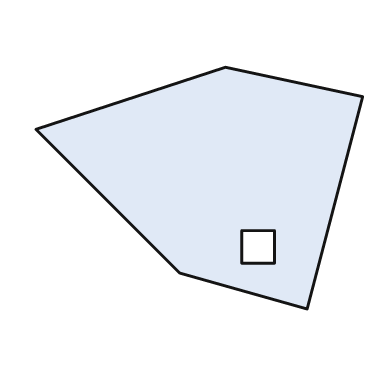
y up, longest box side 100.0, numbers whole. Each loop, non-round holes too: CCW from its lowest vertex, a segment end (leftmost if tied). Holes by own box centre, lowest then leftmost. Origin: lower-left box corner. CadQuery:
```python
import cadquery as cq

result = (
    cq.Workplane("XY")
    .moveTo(83.0, 0.0)
    .lineTo(100.0, 65.0)
    .lineTo(58.0, 74.0)
    .lineTo(0.0, 55.0)
    .lineTo(44.0, 11.0)
    .close()
    .moveTo(63.0, 14.0)
    .lineTo(73.0, 14.0)
    .lineTo(73.0, 24.0)
    .lineTo(63.0, 24.0)
    .close()
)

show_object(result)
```